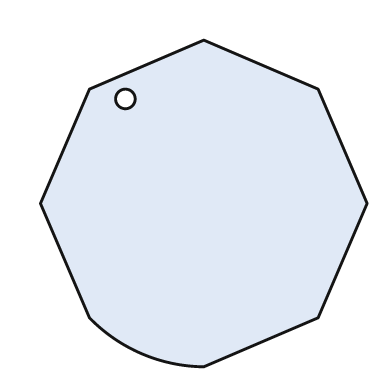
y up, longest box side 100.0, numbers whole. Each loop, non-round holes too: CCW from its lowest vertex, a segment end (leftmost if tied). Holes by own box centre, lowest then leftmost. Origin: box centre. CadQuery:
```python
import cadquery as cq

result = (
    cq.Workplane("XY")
    .moveTo(0.0, -50.0)
    .lineTo(35.0, -35.0)
    .lineTo(50.0, 0.0)
    .lineTo(35.0, 35.0)
    .lineTo(0.0, 50.0)
    .lineTo(-35.0, 35.0)
    .lineTo(-50.0, 0.0)
    .lineTo(-35.0, -35.0)
    .threePointArc((-19.0, -46.0), (0.0, -50.0))
    .close()
    .moveTo(-24.0, 32.0)
    .circle(3.0)
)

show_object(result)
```